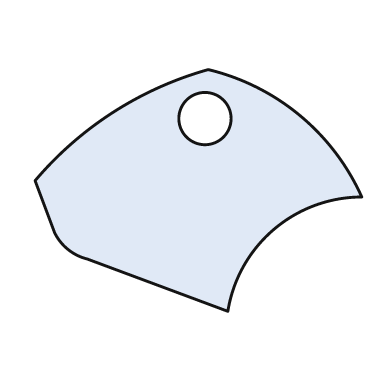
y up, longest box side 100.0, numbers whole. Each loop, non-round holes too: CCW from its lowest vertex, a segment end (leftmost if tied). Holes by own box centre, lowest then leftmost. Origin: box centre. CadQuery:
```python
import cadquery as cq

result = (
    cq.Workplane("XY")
    .moveTo(9.0, -37.0)
    .threePointArc((23.0, -12.0), (50.0, -2.0))
    .threePointArc((31.0, 23.0), (3.0, 37.0))
    .threePointArc((-26.0, 24.0), (-50.0, 3.0))
    .lineTo(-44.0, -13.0)
    .threePointArc((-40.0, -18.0), (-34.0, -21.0))
    .close()
    .moveTo(2.0, 22.0)
    .circle(8.0)
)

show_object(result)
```